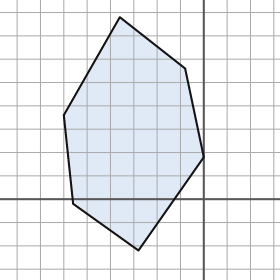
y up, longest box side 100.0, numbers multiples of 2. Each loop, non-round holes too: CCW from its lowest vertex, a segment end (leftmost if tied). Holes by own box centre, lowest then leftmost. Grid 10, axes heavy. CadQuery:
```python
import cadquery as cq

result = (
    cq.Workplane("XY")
    .moveTo(-28.0, -22.0)
    .lineTo(0.0, 18.0)
    .lineTo(-8.0, 56.0)
    .lineTo(-36.0, 78.0)
    .lineTo(-60.0, 36.0)
    .lineTo(-56.0, -2.0)
    .close()
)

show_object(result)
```